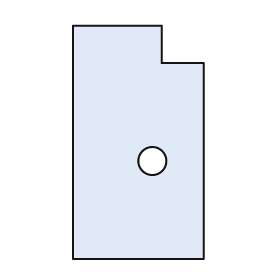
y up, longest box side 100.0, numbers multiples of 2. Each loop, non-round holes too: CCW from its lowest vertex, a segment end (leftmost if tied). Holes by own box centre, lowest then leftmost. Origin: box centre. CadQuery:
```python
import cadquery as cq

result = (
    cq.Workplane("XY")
    .moveTo(-28.0, -50.0)
    .lineTo(28.0, -50.0)
    .lineTo(28.0, 34.0)
    .lineTo(10.0, 34.0)
    .lineTo(10.0, 50.0)
    .lineTo(-28.0, 50.0)
    .close()
    .moveTo(6.0, -8.0)
    .circle(6.0)
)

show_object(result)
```